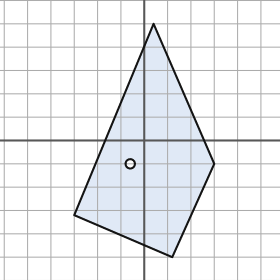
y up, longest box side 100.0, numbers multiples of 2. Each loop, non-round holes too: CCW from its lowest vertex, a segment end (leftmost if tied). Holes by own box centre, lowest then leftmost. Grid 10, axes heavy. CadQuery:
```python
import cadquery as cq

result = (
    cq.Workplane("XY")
    .moveTo(12.0, -50.0)
    .lineTo(30.0, -10.0)
    .lineTo(4.0, 50.0)
    .lineTo(-30.0, -32.0)
    .close()
    .moveTo(-6.0, -10.0)
    .circle(2.0)
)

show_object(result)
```